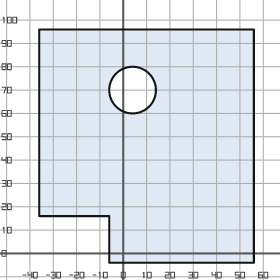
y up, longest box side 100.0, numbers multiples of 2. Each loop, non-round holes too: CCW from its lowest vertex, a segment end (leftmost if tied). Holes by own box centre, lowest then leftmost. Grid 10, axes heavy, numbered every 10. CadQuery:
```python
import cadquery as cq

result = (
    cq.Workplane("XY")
    .moveTo(-6.0, -4.0)
    .lineTo(56.0, -4.0)
    .lineTo(56.0, 96.0)
    .lineTo(-36.0, 96.0)
    .lineTo(-36.0, 16.0)
    .lineTo(-6.0, 16.0)
    .close()
    .moveTo(4.0, 70.0)
    .circle(10.0)
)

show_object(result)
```